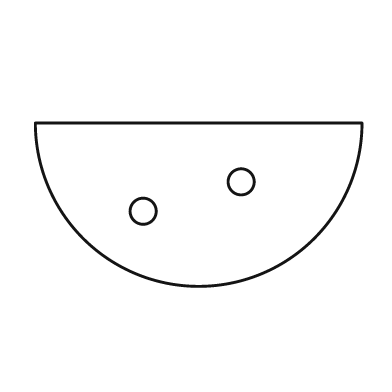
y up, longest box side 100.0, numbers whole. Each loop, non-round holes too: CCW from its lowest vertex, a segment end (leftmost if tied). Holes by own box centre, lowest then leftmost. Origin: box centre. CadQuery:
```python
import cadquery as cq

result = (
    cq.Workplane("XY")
    .moveTo(-50.0, 25.0)
    .threePointArc((0.0, -25.0), (50.0, 25.0))
    .close()
    .moveTo(-17.0, -2.0)
    .circle(4.0)
    .moveTo(13.0, 7.0)
    .circle(4.0)
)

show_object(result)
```